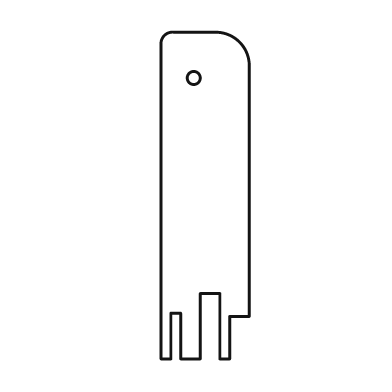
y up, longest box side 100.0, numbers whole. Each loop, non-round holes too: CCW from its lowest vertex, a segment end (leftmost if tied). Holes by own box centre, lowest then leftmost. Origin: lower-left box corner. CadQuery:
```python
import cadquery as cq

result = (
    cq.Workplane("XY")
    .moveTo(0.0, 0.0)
    .lineTo(3.0, 0.0)
    .lineTo(3.0, 14.0)
    .lineTo(6.0, 14.0)
    .lineTo(6.0, 0.0)
    .lineTo(12.0, 0.0)
    .lineTo(12.0, 20.0)
    .lineTo(18.0, 20.0)
    .lineTo(18.0, 0.0)
    .lineTo(21.0, 0.0)
    .lineTo(21.0, 13.0)
    .lineTo(27.0, 13.0)
    .lineTo(27.0, 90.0)
    .threePointArc((24.0, 97.0), (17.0, 100.0))
    .lineTo(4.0, 100.0)
    .threePointArc((1.0, 99.0), (0.0, 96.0))
    .close()
    .moveTo(10.0, 86.0)
    .circle(2.0)
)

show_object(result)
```